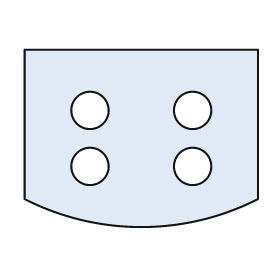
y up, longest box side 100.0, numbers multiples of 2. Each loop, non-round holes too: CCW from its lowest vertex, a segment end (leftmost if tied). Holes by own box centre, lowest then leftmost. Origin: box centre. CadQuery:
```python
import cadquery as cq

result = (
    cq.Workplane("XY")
    .moveTo(-50.0, -26.0)
    .threePointArc((0.0, -38.0), (50.0, -26.0))
    .lineTo(50.0, 38.0)
    .lineTo(-50.0, 38.0)
    .close()
    .moveTo(-22.0, -12.0)
    .circle(8.0)
    .moveTo(22.0, -12.0)
    .circle(8.0)
    .moveTo(-22.0, 12.0)
    .circle(8.0)
    .moveTo(22.0, 12.0)
    .circle(8.0)
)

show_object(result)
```